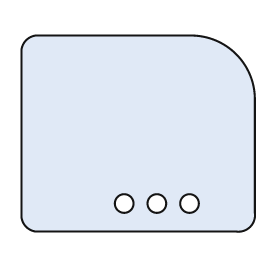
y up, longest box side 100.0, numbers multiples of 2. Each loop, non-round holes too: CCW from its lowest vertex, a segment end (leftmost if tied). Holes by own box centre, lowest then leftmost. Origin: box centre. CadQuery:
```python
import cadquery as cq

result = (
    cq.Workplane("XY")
    .moveTo(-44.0, -42.0)
    .lineTo(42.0, -42.0)
    .threePointArc((48.0, -40.0), (50.0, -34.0))
    .lineTo(50.0, 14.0)
    .threePointArc((42.0, 34.0), (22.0, 42.0))
    .lineTo(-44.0, 42.0)
    .threePointArc((-48.0, 40.0), (-50.0, 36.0))
    .lineTo(-50.0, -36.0)
    .threePointArc((-48.0, -40.0), (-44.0, -42.0))
    .close()
    .moveTo(-6.0, -30.0)
    .circle(4.0)
    .moveTo(8.0, -30.0)
    .circle(4.0)
    .moveTo(22.0, -30.0)
    .circle(4.0)
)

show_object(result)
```